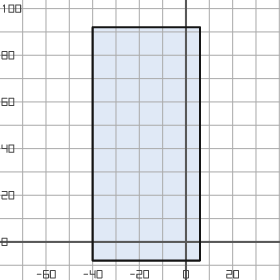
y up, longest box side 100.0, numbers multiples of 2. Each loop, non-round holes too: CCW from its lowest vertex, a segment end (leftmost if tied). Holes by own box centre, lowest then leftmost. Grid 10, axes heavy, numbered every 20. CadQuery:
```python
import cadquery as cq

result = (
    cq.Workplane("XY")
    .moveTo(-40.0, -8.0)
    .lineTo(6.0, -8.0)
    .lineTo(6.0, 92.0)
    .lineTo(-40.0, 92.0)
    .close()
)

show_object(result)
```